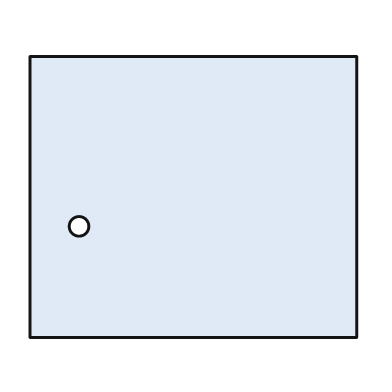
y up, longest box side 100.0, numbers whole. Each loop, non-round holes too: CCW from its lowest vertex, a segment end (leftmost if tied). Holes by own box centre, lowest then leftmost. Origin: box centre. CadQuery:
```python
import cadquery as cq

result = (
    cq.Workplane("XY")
    .moveTo(-50.0, -43.0)
    .lineTo(50.0, -43.0)
    .lineTo(50.0, 43.0)
    .lineTo(-50.0, 43.0)
    .close()
    .moveTo(-35.0, -9.0)
    .circle(3.0)
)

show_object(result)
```